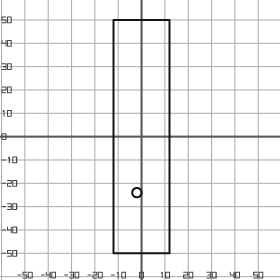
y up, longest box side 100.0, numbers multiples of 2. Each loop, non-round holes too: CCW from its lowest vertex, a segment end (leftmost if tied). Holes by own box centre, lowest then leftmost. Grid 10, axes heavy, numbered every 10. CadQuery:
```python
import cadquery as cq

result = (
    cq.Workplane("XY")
    .moveTo(-12.0, -50.0)
    .lineTo(12.0, -50.0)
    .lineTo(12.0, 50.0)
    .lineTo(-12.0, 50.0)
    .close()
    .moveTo(-2.0, -24.0)
    .circle(2.0)
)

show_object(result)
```